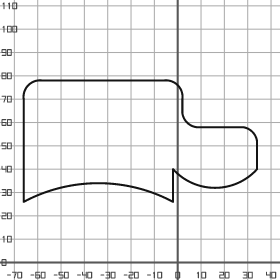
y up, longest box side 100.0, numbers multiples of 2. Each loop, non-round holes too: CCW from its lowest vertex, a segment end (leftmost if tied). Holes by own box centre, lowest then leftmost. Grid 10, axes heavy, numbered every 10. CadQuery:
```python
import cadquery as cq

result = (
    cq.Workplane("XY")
    .moveTo(-66.0, 26.0)
    .threePointArc((-34.0, 34.0), (-2.0, 26.0))
    .lineTo(-2.0, 40.0)
    .threePointArc((16.0, 32.0), (34.0, 40.0))
    .lineTo(34.0, 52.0)
    .threePointArc((32.0, 56.0), (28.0, 58.0))
    .lineTo(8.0, 58.0)
    .threePointArc((4.0, 60.0), (2.0, 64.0))
    .lineTo(2.0, 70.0)
    .threePointArc((0.0, 76.0), (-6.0, 78.0))
    .lineTo(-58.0, 78.0)
    .threePointArc((-64.0, 76.0), (-66.0, 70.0))
    .close()
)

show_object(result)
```